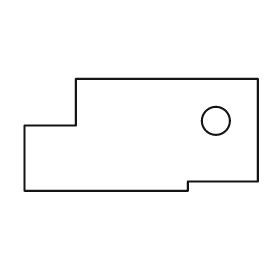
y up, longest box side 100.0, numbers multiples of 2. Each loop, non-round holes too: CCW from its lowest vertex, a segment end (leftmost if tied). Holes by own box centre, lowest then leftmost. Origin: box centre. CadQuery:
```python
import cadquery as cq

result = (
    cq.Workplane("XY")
    .moveTo(-50.0, -24.0)
    .lineTo(20.0, -24.0)
    .lineTo(20.0, -20.0)
    .lineTo(50.0, -20.0)
    .lineTo(50.0, 24.0)
    .lineTo(-28.0, 24.0)
    .lineTo(-28.0, 4.0)
    .lineTo(-50.0, 4.0)
    .close()
    .moveTo(32.0, 6.0)
    .circle(6.0)
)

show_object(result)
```